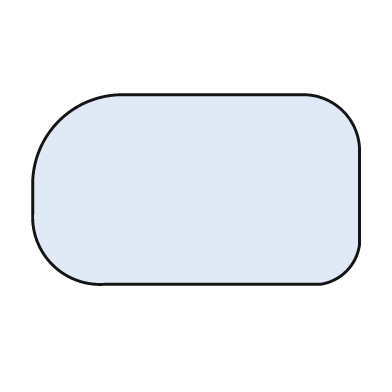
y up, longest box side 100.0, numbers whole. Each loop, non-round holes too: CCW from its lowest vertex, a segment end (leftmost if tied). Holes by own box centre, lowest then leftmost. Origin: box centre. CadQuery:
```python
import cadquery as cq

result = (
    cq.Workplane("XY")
    .moveTo(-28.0, -29.0)
    .lineTo(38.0, -29.0)
    .threePointArc((46.0, -25.0), (50.0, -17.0))
    .lineTo(50.0, 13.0)
    .threePointArc((45.0, 24.0), (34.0, 29.0))
    .lineTo(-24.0, 29.0)
    .threePointArc((-42.0, 21.0), (-50.0, 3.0))
    .lineTo(-50.0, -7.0)
    .threePointArc((-44.0, -23.0), (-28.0, -29.0))
    .close()
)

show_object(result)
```